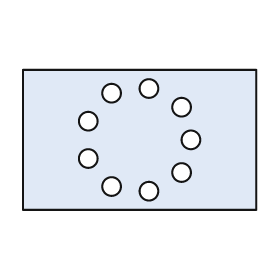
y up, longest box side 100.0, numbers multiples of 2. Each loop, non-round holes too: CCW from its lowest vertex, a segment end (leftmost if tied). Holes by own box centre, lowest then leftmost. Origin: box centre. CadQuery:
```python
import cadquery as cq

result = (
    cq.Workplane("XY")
    .moveTo(-50.0, -30.0)
    .lineTo(50.0, -30.0)
    .lineTo(50.0, 30.0)
    .lineTo(-50.0, 30.0)
    .close()
    .moveTo(4.0, -22.0)
    .circle(4.0)
    .moveTo(-12.0, -20.0)
    .circle(4.0)
    .moveTo(18.0, -14.0)
    .circle(4.0)
    .moveTo(-22.0, -8.0)
    .circle(4.0)
    .moveTo(22.0, 0.0)
    .circle(4.0)
    .moveTo(-22.0, 8.0)
    .circle(4.0)
    .moveTo(18.0, 14.0)
    .circle(4.0)
    .moveTo(-12.0, 20.0)
    .circle(4.0)
    .moveTo(4.0, 22.0)
    .circle(4.0)
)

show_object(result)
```